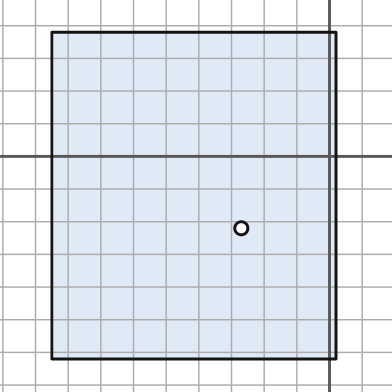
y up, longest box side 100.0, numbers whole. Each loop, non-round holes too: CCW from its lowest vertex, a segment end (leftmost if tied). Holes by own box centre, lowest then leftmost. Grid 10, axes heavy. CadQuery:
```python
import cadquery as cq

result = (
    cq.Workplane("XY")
    .moveTo(-85.0, -62.0)
    .lineTo(2.0, -62.0)
    .lineTo(2.0, 38.0)
    .lineTo(-85.0, 38.0)
    .close()
    .moveTo(-27.0, -22.0)
    .circle(2.0)
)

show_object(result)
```